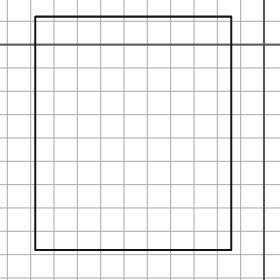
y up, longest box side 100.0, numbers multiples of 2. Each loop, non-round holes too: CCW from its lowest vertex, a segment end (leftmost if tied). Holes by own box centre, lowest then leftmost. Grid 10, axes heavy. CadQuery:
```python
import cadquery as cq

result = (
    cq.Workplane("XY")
    .moveTo(-98.0, -88.0)
    .lineTo(-14.0, -88.0)
    .lineTo(-14.0, 12.0)
    .lineTo(-98.0, 12.0)
    .close()
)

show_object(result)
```